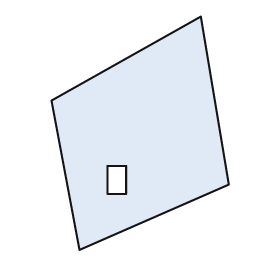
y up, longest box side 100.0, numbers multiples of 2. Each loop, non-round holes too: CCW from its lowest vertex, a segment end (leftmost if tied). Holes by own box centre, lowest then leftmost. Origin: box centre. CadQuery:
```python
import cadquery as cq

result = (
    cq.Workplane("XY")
    .moveTo(-26.0, -50.0)
    .lineTo(38.0, -22.0)
    .lineTo(26.0, 50.0)
    .lineTo(-38.0, 14.0)
    .close()
    .moveTo(-14.0, -26.0)
    .lineTo(-6.0, -26.0)
    .lineTo(-6.0, -14.0)
    .lineTo(-14.0, -14.0)
    .close()
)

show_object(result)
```